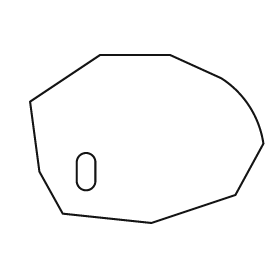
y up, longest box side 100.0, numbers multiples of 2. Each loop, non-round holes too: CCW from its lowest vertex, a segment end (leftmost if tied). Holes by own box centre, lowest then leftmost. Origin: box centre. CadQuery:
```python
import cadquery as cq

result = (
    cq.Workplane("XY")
    .moveTo(2.0, -36.0)
    .lineTo(38.0, -24.0)
    .lineTo(50.0, -2.0)
    .threePointArc((44.0, 14.0), (32.0, 26.0))
    .lineTo(10.0, 36.0)
    .lineTo(-20.0, 36.0)
    .lineTo(-50.0, 16.0)
    .lineTo(-46.0, -14.0)
    .lineTo(-36.0, -32.0)
    .close()
    .moveTo(-30.0, -18.0)
    .threePointArc((-26.0, -22.0), (-22.0, -18.0))
    .lineTo(-22.0, -10.0)
    .threePointArc((-26.0, -6.0), (-30.0, -10.0))
    .close()
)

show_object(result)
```